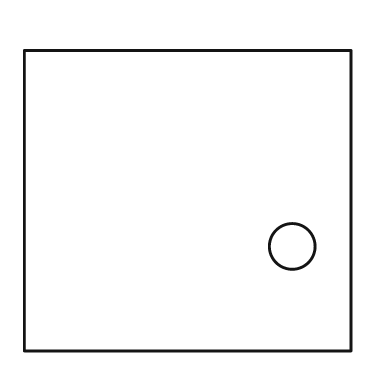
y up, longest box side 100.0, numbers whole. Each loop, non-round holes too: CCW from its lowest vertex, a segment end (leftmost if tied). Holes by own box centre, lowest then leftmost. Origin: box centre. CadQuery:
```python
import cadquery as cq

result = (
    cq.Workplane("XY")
    .moveTo(-50.0, -46.0)
    .lineTo(50.0, -46.0)
    .lineTo(50.0, 46.0)
    .lineTo(-50.0, 46.0)
    .close()
    .moveTo(32.0, -14.0)
    .circle(7.0)
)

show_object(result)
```